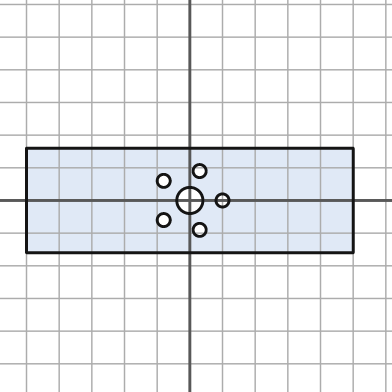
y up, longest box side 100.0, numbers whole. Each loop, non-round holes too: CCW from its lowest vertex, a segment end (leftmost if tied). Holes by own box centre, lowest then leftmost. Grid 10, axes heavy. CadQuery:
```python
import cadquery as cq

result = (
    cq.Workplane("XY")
    .moveTo(-50.0, -16.0)
    .lineTo(50.0, -16.0)
    .lineTo(50.0, 16.0)
    .lineTo(-50.0, 16.0)
    .close()
    .moveTo(3.0, -9.0)
    .circle(2.0)
    .moveTo(-8.0, -6.0)
    .circle(2.0)
    .moveTo(0.0, 0.0)
    .circle(4.0)
    .moveTo(10.0, 0.0)
    .circle(2.0)
    .moveTo(-8.0, 6.0)
    .circle(2.0)
    .moveTo(3.0, 9.0)
    .circle(2.0)
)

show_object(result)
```